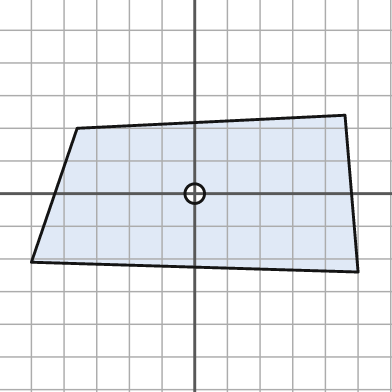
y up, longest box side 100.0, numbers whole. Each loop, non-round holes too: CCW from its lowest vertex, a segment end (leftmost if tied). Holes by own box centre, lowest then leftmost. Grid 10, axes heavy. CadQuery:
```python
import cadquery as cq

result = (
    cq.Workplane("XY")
    .moveTo(50.0, -24.0)
    .lineTo(46.0, 24.0)
    .lineTo(-36.0, 20.0)
    .lineTo(-50.0, -21.0)
    .close()
    .moveTo(0.0, 0.0)
    .circle(3.0)
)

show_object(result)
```